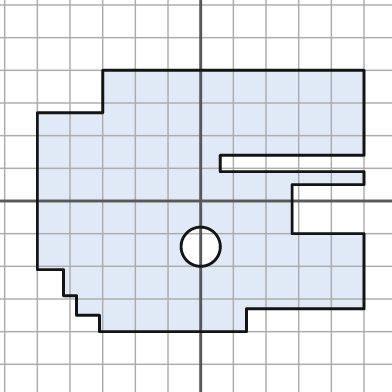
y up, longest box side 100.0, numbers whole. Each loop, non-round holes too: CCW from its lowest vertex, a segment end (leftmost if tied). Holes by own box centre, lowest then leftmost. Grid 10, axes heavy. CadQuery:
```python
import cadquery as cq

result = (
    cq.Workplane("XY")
    .moveTo(-31.0, -40.0)
    .lineTo(14.0, -40.0)
    .lineTo(14.0, -33.0)
    .lineTo(50.0, -33.0)
    .lineTo(50.0, -10.0)
    .lineTo(28.0, -10.0)
    .lineTo(28.0, 5.0)
    .lineTo(50.0, 5.0)
    .lineTo(50.0, 9.0)
    .lineTo(6.0, 9.0)
    .lineTo(6.0, 14.0)
    .lineTo(50.0, 14.0)
    .lineTo(50.0, 40.0)
    .lineTo(-30.0, 40.0)
    .lineTo(-30.0, 27.0)
    .lineTo(-50.0, 27.0)
    .lineTo(-50.0, -21.0)
    .lineTo(-42.0, -21.0)
    .lineTo(-42.0, -29.0)
    .lineTo(-38.0, -29.0)
    .lineTo(-38.0, -35.0)
    .lineTo(-31.0, -35.0)
    .close()
    .moveTo(0.0, -14.0)
    .circle(6.0)
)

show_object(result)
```